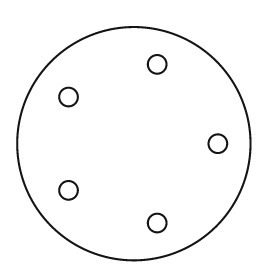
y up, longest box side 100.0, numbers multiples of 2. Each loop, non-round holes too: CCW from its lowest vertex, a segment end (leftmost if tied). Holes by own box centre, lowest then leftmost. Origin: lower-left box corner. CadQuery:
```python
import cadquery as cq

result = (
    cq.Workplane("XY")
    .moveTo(50.0, 50.0)
    .circle(50.0)
    .moveTo(60.0, 16.0)
    .circle(4.0)
    .moveTo(22.0, 30.0)
    .circle(4.0)
    .moveTo(86.0, 50.0)
    .circle(4.0)
    .moveTo(22.0, 70.0)
    .circle(4.0)
    .moveTo(60.0, 84.0)
    .circle(4.0)
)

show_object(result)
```